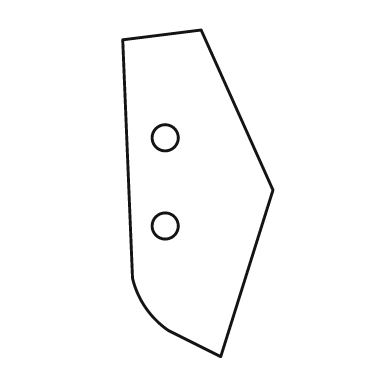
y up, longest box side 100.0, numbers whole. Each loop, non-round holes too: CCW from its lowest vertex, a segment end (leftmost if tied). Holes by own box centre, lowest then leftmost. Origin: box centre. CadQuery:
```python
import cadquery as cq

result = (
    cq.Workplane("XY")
    .moveTo(7.0, -50.0)
    .lineTo(23.0, 1.0)
    .lineTo(1.0, 50.0)
    .lineTo(-23.0, 47.0)
    .lineTo(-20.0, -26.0)
    .threePointArc((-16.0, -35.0), (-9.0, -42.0))
    .close()
    .moveTo(-10.0, -10.0)
    .circle(4.0)
    .moveTo(-10.0, 17.0)
    .circle(4.0)
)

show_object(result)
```